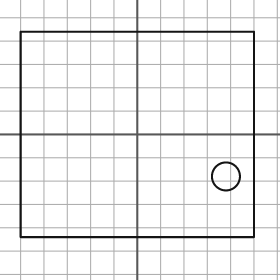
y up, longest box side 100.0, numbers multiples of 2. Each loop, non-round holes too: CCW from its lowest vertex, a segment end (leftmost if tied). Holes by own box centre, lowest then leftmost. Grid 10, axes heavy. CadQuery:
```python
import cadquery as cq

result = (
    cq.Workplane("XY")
    .moveTo(-50.0, -44.0)
    .lineTo(50.0, -44.0)
    .lineTo(50.0, 44.0)
    .lineTo(-50.0, 44.0)
    .close()
    .moveTo(38.0, -18.0)
    .circle(6.0)
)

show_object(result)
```